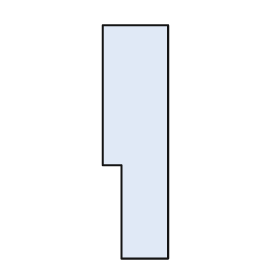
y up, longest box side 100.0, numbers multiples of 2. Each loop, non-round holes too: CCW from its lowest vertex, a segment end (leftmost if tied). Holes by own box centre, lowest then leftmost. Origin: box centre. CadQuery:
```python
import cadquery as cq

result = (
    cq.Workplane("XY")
    .moveTo(-6.0, -50.0)
    .lineTo(14.0, -50.0)
    .lineTo(14.0, 50.0)
    .lineTo(-14.0, 50.0)
    .lineTo(-14.0, -10.0)
    .lineTo(-6.0, -10.0)
    .close()
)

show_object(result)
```